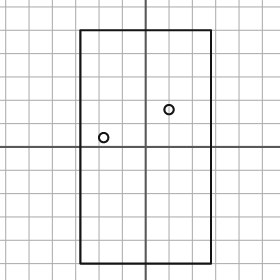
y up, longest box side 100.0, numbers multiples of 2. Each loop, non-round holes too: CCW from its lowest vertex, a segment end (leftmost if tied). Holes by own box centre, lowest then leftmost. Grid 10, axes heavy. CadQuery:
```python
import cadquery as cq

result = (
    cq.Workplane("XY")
    .moveTo(-28.0, -50.0)
    .lineTo(28.0, -50.0)
    .lineTo(28.0, 50.0)
    .lineTo(-28.0, 50.0)
    .close()
    .moveTo(-18.0, 4.0)
    .circle(2.0)
    .moveTo(10.0, 16.0)
    .circle(2.0)
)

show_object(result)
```